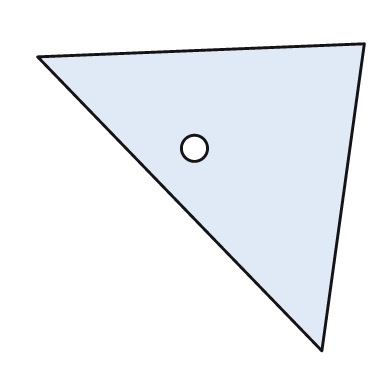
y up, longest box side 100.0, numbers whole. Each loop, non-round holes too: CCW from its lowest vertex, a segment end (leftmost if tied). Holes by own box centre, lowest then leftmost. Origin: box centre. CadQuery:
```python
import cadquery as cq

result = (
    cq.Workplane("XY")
    .moveTo(37.0, -47.0)
    .lineTo(50.0, 47.0)
    .lineTo(-50.0, 43.0)
    .close()
    .moveTo(-2.0, 15.0)
    .circle(4.0)
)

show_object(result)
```